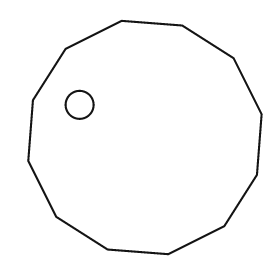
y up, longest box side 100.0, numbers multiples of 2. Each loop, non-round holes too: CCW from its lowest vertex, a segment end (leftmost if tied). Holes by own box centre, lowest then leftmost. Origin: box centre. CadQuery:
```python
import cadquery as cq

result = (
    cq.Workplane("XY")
    .moveTo(10.0, -50.0)
    .lineTo(34.0, -38.0)
    .lineTo(48.0, -16.0)
    .lineTo(50.0, 10.0)
    .lineTo(38.0, 34.0)
    .lineTo(16.0, 48.0)
    .lineTo(-10.0, 50.0)
    .lineTo(-34.0, 38.0)
    .lineTo(-48.0, 16.0)
    .lineTo(-50.0, -10.0)
    .lineTo(-38.0, -34.0)
    .lineTo(-16.0, -48.0)
    .close()
    .moveTo(-28.0, 14.0)
    .circle(6.0)
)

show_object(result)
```